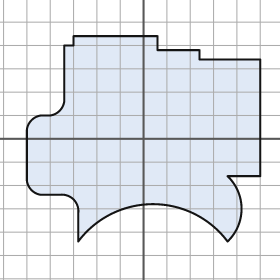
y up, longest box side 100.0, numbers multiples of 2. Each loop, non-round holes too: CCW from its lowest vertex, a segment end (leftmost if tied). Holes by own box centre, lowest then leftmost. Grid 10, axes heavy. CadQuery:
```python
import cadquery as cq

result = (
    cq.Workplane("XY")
    .moveTo(-28.0, -44.0)
    .threePointArc((4.0, -28.0), (36.0, -44.0))
    .threePointArc((42.0, -30.0), (36.0, -16.0))
    .lineTo(50.0, -16.0)
    .lineTo(50.0, 34.0)
    .lineTo(24.0, 34.0)
    .lineTo(24.0, 38.0)
    .lineTo(6.0, 38.0)
    .lineTo(6.0, 44.0)
    .lineTo(-30.0, 44.0)
    .lineTo(-30.0, 40.0)
    .lineTo(-34.0, 40.0)
    .lineTo(-34.0, 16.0)
    .threePointArc((-36.0, 12.0), (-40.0, 10.0))
    .lineTo(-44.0, 10.0)
    .threePointArc((-48.0, 8.0), (-50.0, 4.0))
    .lineTo(-50.0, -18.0)
    .threePointArc((-48.0, -22.0), (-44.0, -24.0))
    .lineTo(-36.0, -24.0)
    .threePointArc((-30.0, -26.0), (-28.0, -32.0))
    .close()
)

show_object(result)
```